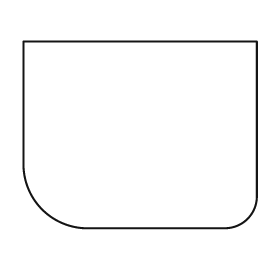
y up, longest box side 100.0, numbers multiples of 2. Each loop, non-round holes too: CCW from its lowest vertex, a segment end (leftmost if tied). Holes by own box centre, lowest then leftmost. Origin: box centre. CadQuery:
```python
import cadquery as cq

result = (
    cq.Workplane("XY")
    .moveTo(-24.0, -40.0)
    .lineTo(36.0, -40.0)
    .threePointArc((46.0, -36.0), (50.0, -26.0))
    .lineTo(50.0, 40.0)
    .lineTo(-50.0, 40.0)
    .lineTo(-50.0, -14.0)
    .threePointArc((-42.0, -32.0), (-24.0, -40.0))
    .close()
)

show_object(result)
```